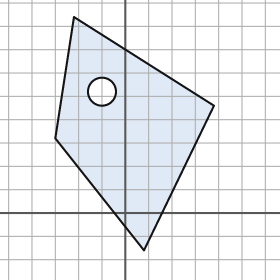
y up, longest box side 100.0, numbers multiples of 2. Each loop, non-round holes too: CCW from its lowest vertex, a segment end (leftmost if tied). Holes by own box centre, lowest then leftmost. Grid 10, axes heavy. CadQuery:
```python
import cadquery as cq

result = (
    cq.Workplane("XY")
    .moveTo(8.0, -16.0)
    .lineTo(38.0, 46.0)
    .lineTo(-22.0, 84.0)
    .lineTo(-30.0, 32.0)
    .close()
    .moveTo(-10.0, 52.0)
    .circle(6.0)
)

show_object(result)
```